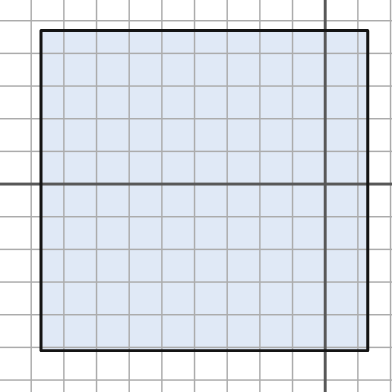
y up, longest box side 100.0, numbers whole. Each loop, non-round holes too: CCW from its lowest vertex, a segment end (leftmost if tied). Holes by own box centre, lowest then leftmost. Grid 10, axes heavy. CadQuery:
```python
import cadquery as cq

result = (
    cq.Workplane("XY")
    .moveTo(-87.0, -51.0)
    .lineTo(13.0, -51.0)
    .lineTo(13.0, 47.0)
    .lineTo(-87.0, 47.0)
    .close()
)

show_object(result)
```